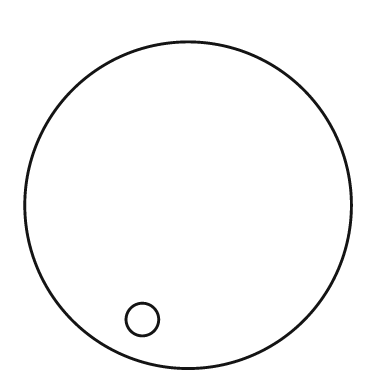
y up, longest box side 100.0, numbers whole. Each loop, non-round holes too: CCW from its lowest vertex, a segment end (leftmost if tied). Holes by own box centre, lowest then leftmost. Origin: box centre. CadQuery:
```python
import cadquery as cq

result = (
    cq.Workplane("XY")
    .moveTo(0.0, 0.0)
    .circle(50.0)
    .moveTo(-14.0, -35.0)
    .circle(5.0)
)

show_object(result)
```